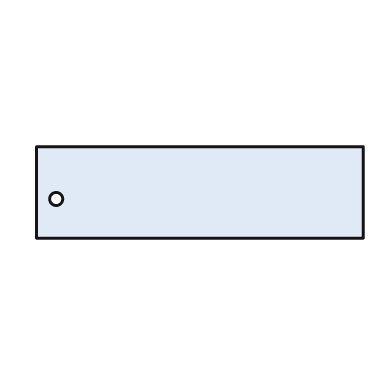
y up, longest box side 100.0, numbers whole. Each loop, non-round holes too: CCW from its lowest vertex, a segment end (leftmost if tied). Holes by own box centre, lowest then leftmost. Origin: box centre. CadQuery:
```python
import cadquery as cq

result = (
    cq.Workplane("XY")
    .moveTo(-50.0, -14.0)
    .lineTo(50.0, -14.0)
    .lineTo(50.0, 14.0)
    .lineTo(-50.0, 14.0)
    .close()
    .moveTo(-44.0, -2.0)
    .circle(2.0)
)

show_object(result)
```